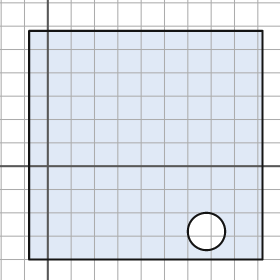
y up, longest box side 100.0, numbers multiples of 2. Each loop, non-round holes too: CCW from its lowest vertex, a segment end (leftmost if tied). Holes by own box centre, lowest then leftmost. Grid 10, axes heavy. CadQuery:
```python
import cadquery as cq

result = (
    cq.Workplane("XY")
    .moveTo(-8.0, -40.0)
    .lineTo(92.0, -40.0)
    .lineTo(92.0, 58.0)
    .lineTo(-8.0, 58.0)
    .close()
    .moveTo(68.0, -28.0)
    .circle(8.0)
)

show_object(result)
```